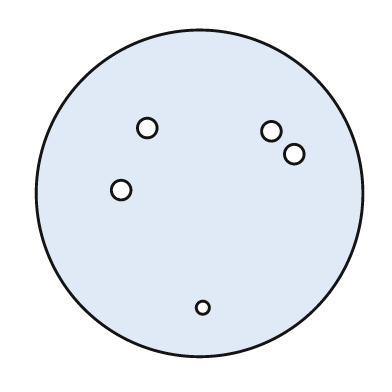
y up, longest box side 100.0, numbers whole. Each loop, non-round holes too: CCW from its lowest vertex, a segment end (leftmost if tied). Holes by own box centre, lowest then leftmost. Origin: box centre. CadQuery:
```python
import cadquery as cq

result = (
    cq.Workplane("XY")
    .moveTo(0.0, 0.0)
    .circle(50.0)
    .moveTo(1.0, -35.0)
    .circle(2.0)
    .moveTo(-24.0, 1.0)
    .circle(3.0)
    .moveTo(29.0, 12.0)
    .circle(3.0)
    .moveTo(22.0, 19.0)
    .circle(3.0)
    .moveTo(-16.0, 20.0)
    .circle(3.0)
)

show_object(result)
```